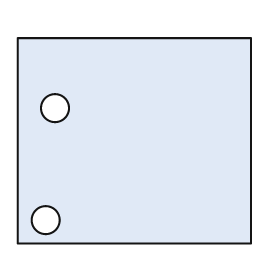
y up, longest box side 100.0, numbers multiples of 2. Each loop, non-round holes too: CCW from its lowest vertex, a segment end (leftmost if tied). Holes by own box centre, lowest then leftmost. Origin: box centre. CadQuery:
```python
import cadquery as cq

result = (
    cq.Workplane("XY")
    .moveTo(-50.0, -44.0)
    .lineTo(50.0, -44.0)
    .lineTo(50.0, 44.0)
    .lineTo(-50.0, 44.0)
    .close()
    .moveTo(-38.0, -34.0)
    .circle(6.0)
    .moveTo(-34.0, 14.0)
    .circle(6.0)
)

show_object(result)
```